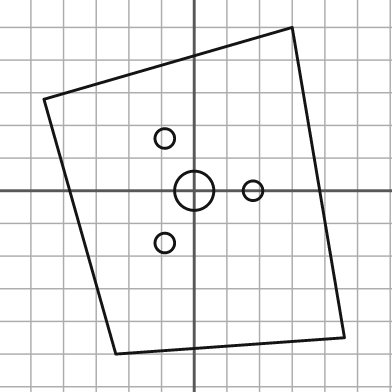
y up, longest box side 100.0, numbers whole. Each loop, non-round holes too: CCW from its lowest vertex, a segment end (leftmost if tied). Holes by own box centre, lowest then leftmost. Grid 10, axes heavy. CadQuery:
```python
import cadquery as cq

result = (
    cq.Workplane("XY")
    .moveTo(-24.0, -50.0)
    .lineTo(46.0, -45.0)
    .lineTo(30.0, 50.0)
    .lineTo(-46.0, 28.0)
    .close()
    .moveTo(-9.0, -16.0)
    .circle(3.0)
    .moveTo(0.0, 0.0)
    .circle(6.0)
    .moveTo(18.0, 0.0)
    .circle(3.0)
    .moveTo(-9.0, 16.0)
    .circle(3.0)
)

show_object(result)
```